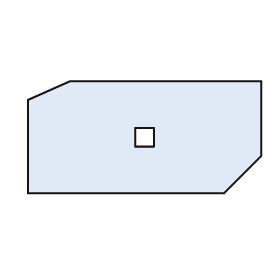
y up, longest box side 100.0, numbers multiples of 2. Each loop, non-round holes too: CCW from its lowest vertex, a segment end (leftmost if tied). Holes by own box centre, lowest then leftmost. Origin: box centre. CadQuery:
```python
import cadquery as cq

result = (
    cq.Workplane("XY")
    .moveTo(-50.0, -24.0)
    .lineTo(34.0, -24.0)
    .lineTo(50.0, -8.0)
    .lineTo(50.0, 24.0)
    .lineTo(-32.0, 24.0)
    .lineTo(-50.0, 16.0)
    .close()
    .moveTo(-4.0, -4.0)
    .lineTo(4.0, -4.0)
    .lineTo(4.0, 4.0)
    .lineTo(-4.0, 4.0)
    .close()
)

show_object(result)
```